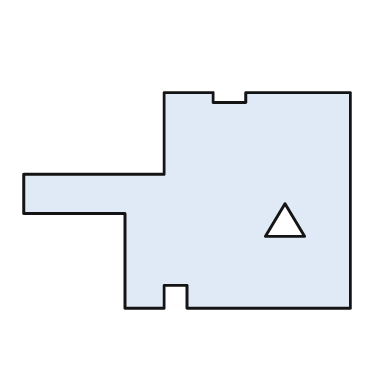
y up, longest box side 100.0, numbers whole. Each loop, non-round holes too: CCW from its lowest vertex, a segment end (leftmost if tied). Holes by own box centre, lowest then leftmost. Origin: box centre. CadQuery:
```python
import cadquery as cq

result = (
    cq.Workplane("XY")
    .moveTo(-19.0, -33.0)
    .lineTo(-7.0, -33.0)
    .lineTo(-7.0, -26.0)
    .lineTo(0.0, -26.0)
    .lineTo(0.0, -33.0)
    .lineTo(50.0, -33.0)
    .lineTo(50.0, 33.0)
    .lineTo(18.0, 33.0)
    .lineTo(18.0, 30.0)
    .lineTo(8.0, 30.0)
    .lineTo(8.0, 33.0)
    .lineTo(-7.0, 33.0)
    .lineTo(-7.0, 8.0)
    .lineTo(-50.0, 8.0)
    .lineTo(-50.0, -4.0)
    .lineTo(-19.0, -4.0)
    .close()
    .moveTo(24.0, -11.0)
    .lineTo(36.0, -11.0)
    .lineTo(30.0, -1.0)
    .close()
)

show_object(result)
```